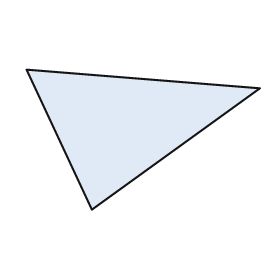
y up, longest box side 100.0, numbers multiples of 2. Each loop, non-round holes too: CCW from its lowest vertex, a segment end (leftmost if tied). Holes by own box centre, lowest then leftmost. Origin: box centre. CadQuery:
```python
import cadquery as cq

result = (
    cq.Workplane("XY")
    .moveTo(-22.0, -30.0)
    .lineTo(50.0, 22.0)
    .lineTo(-50.0, 30.0)
    .close()
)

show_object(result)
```